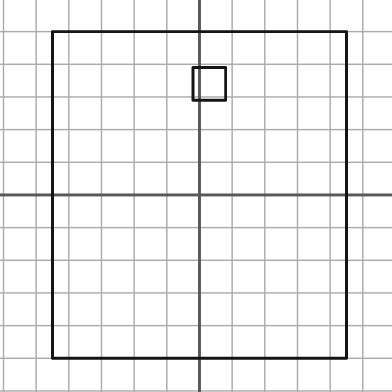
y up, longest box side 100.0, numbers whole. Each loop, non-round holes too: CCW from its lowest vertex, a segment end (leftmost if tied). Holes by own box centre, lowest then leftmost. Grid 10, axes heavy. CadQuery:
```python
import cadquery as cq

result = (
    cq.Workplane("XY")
    .moveTo(-45.0, -50.0)
    .lineTo(45.0, -50.0)
    .lineTo(45.0, 50.0)
    .lineTo(-45.0, 50.0)
    .close()
    .moveTo(-2.0, 29.0)
    .lineTo(8.0, 29.0)
    .lineTo(8.0, 39.0)
    .lineTo(-2.0, 39.0)
    .close()
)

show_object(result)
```